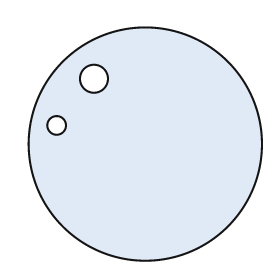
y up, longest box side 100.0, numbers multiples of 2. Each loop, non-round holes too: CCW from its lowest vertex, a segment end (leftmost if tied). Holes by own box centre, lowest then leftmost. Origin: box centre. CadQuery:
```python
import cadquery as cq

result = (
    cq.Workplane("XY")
    .moveTo(0.0, 0.0)
    .circle(50.0)
    .moveTo(-38.0, 8.0)
    .circle(4.0)
    .moveTo(-22.0, 28.0)
    .circle(6.0)
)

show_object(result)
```